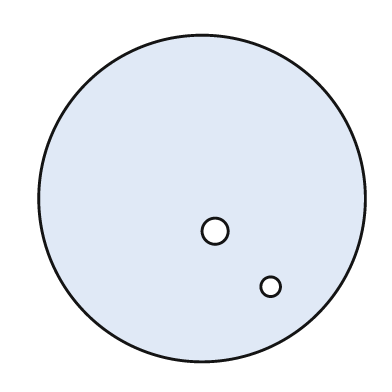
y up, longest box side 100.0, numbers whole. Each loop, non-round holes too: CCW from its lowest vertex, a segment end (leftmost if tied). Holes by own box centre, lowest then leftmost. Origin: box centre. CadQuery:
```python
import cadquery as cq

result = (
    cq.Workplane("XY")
    .moveTo(0.0, 0.0)
    .circle(50.0)
    .moveTo(21.0, -27.0)
    .circle(3.0)
    .moveTo(4.0, -10.0)
    .circle(4.0)
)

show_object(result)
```